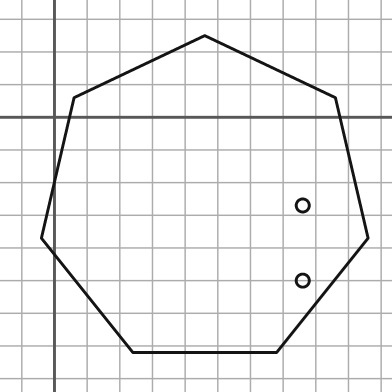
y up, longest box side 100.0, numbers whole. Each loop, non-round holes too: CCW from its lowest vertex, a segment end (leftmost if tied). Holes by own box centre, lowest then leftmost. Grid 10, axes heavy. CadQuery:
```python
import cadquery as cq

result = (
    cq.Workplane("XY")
    .moveTo(24.0, -72.0)
    .lineTo(68.0, -72.0)
    .lineTo(96.0, -37.0)
    .lineTo(86.0, 6.0)
    .lineTo(46.0, 25.0)
    .lineTo(6.0, 6.0)
    .lineTo(-4.0, -37.0)
    .close()
    .moveTo(76.0, -50.0)
    .circle(2.0)
    .moveTo(76.0, -27.0)
    .circle(2.0)
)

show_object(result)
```